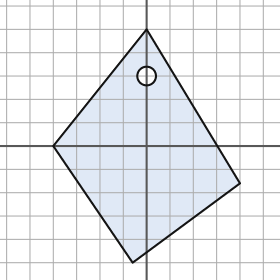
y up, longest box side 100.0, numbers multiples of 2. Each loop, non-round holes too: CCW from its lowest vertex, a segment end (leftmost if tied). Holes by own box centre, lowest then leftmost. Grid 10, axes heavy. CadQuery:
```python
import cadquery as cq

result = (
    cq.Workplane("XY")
    .moveTo(-6.0, -50.0)
    .lineTo(40.0, -16.0)
    .lineTo(0.0, 50.0)
    .lineTo(-40.0, 0.0)
    .close()
    .moveTo(0.0, 30.0)
    .circle(4.0)
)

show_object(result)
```